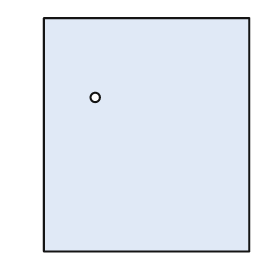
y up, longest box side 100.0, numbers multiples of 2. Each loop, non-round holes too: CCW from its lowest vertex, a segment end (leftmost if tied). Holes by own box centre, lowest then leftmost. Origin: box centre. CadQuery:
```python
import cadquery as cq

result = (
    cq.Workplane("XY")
    .moveTo(-44.0, -50.0)
    .lineTo(44.0, -50.0)
    .lineTo(44.0, 50.0)
    .lineTo(-44.0, 50.0)
    .close()
    .moveTo(-22.0, 16.0)
    .circle(2.0)
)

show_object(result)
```